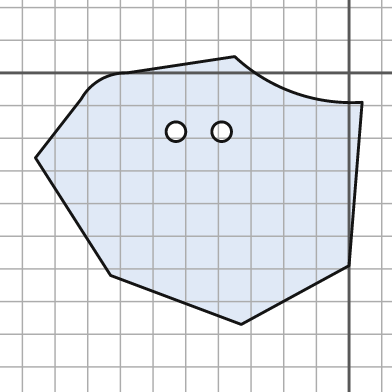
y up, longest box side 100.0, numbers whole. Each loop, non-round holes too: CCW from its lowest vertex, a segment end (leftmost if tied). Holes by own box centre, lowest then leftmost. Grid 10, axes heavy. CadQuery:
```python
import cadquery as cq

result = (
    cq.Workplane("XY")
    .moveTo(-33.0, -77.0)
    .lineTo(0.0, -59.0)
    .lineTo(4.0, -9.0)
    .threePointArc((-17.0, -6.0), (-35.0, 5.0))
    .lineTo(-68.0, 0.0)
    .threePointArc((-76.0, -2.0), (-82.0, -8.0))
    .lineTo(-96.0, -26.0)
    .lineTo(-73.0, -62.0)
    .close()
    .moveTo(-53.0, -18.0)
    .circle(3.0)
    .moveTo(-39.0, -18.0)
    .circle(3.0)
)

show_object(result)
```